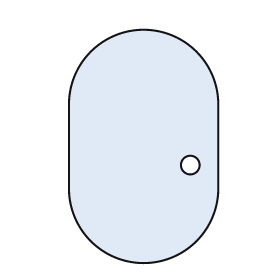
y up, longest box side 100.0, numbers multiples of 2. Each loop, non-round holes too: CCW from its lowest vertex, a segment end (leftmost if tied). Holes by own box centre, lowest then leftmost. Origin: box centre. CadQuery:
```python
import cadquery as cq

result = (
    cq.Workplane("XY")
    .moveTo(-32.0, -18.0)
    .threePointArc((0.0, -50.0), (32.0, -18.0))
    .lineTo(32.0, 18.0)
    .threePointArc((0.0, 50.0), (-32.0, 18.0))
    .close()
    .moveTo(20.0, -8.0)
    .circle(4.0)
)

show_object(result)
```